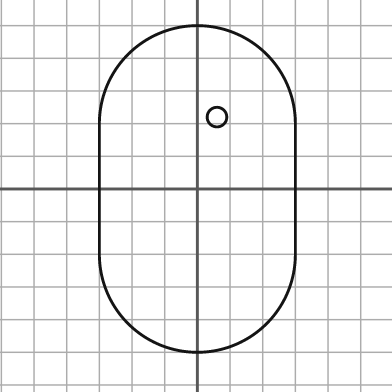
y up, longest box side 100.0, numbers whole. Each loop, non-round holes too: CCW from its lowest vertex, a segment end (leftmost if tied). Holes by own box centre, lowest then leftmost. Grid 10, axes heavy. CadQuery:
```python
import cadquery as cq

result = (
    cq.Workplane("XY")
    .moveTo(-30.0, -20.0)
    .threePointArc((0.0, -50.0), (30.0, -20.0))
    .lineTo(30.0, 20.0)
    .threePointArc((0.0, 50.0), (-30.0, 20.0))
    .close()
    .moveTo(6.0, 22.0)
    .circle(3.0)
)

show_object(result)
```